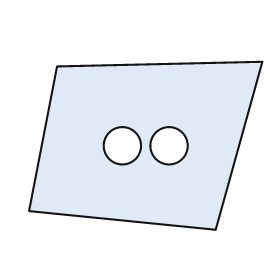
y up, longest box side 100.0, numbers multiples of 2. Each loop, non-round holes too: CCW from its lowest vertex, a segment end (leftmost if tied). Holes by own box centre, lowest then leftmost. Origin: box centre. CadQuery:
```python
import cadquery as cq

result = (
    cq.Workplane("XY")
    .moveTo(30.0, -36.0)
    .lineTo(50.0, 36.0)
    .lineTo(-38.0, 34.0)
    .lineTo(-50.0, -28.0)
    .close()
    .moveTo(-10.0, 0.0)
    .circle(8.0)
    .moveTo(10.0, 0.0)
    .circle(8.0)
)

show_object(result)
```